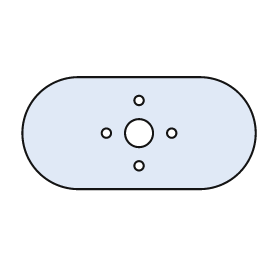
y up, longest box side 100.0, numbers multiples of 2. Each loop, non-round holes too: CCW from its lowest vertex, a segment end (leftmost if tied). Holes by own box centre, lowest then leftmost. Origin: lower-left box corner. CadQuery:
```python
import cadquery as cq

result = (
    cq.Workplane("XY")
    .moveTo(24.0, 0.0)
    .lineTo(76.0, 0.0)
    .threePointArc((100.0, 24.0), (76.0, 48.0))
    .lineTo(24.0, 48.0)
    .threePointArc((0.0, 24.0), (24.0, 0.0))
    .close()
    .moveTo(50.0, 10.0)
    .circle(2.0)
    .moveTo(36.0, 24.0)
    .circle(2.0)
    .moveTo(50.0, 24.0)
    .circle(6.0)
    .moveTo(64.0, 24.0)
    .circle(2.0)
    .moveTo(50.0, 38.0)
    .circle(2.0)
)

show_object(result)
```